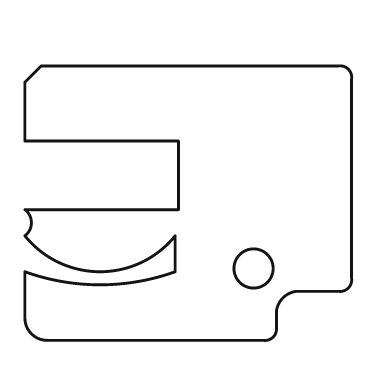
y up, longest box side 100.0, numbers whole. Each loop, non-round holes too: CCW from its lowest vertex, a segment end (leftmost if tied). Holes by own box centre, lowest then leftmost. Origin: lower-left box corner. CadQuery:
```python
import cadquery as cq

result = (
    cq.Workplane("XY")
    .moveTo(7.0, 0.0)
    .lineTo(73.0, 0.0)
    .threePointArc((76.0, 1.0), (77.0, 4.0))
    .lineTo(77.0, 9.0)
    .threePointArc((79.0, 13.0), (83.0, 15.0))
    .lineTo(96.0, 15.0)
    .threePointArc((99.0, 16.0), (100.0, 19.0))
    .lineTo(100.0, 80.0)
    .threePointArc((99.0, 83.0), (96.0, 84.0))
    .lineTo(5.0, 84.0)
    .lineTo(0.0, 79.0)
    .lineTo(0.0, 61.0)
    .lineTo(47.0, 61.0)
    .lineTo(47.0, 40.0)
    .lineTo(0.0, 40.0)
    .threePointArc((2.0, 36.0), (0.0, 32.0))
    .threePointArc((23.0, 21.0), (46.0, 32.0))
    .lineTo(46.0, 21.0)
    .threePointArc((23.0, 17.0), (0.0, 21.0))
    .lineTo(0.0, 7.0)
    .threePointArc((2.0, 2.0), (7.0, 0.0))
    .close()
    .moveTo(70.0, 22.0)
    .circle(6.0)
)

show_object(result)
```